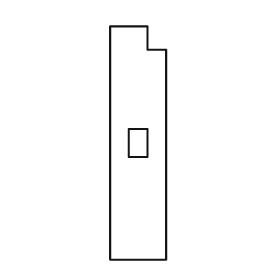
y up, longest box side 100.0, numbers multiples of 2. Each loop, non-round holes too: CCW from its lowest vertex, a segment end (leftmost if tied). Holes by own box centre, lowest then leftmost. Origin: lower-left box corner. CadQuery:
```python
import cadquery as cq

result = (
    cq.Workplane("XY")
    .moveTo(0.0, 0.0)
    .lineTo(24.0, 0.0)
    .lineTo(24.0, 90.0)
    .lineTo(16.0, 90.0)
    .lineTo(16.0, 100.0)
    .lineTo(0.0, 100.0)
    .close()
    .moveTo(8.0, 44.0)
    .lineTo(16.0, 44.0)
    .lineTo(16.0, 56.0)
    .lineTo(8.0, 56.0)
    .close()
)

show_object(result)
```